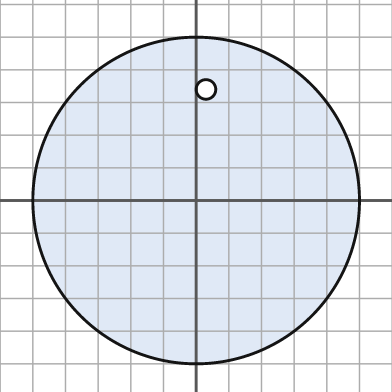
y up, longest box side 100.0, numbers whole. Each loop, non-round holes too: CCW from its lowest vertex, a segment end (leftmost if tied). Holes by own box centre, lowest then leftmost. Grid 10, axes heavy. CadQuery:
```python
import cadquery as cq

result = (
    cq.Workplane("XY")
    .moveTo(0.0, 0.0)
    .circle(50.0)
    .moveTo(3.0, 34.0)
    .circle(3.0)
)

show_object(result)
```